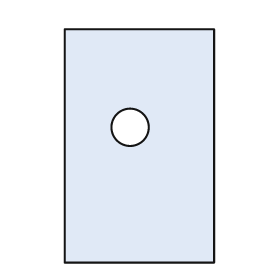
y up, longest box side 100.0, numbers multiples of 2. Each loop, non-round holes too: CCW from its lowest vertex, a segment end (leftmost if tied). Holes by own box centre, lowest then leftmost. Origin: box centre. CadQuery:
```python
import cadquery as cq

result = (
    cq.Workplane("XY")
    .moveTo(-32.0, -50.0)
    .lineTo(32.0, -50.0)
    .lineTo(32.0, 50.0)
    .lineTo(-32.0, 50.0)
    .close()
    .moveTo(-4.0, 8.0)
    .circle(8.0)
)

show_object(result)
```